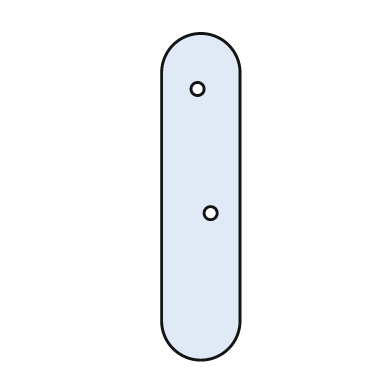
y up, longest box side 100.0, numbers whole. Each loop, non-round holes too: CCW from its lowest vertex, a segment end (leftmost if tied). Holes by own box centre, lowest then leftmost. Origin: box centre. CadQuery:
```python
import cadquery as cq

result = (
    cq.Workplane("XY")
    .moveTo(-12.0, -38.0)
    .threePointArc((0.0, -50.0), (12.0, -38.0))
    .lineTo(12.0, 38.0)
    .threePointArc((0.0, 50.0), (-12.0, 38.0))
    .close()
    .moveTo(3.0, -5.0)
    .circle(2.0)
    .moveTo(-1.0, 33.0)
    .circle(2.0)
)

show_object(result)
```